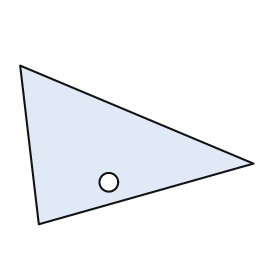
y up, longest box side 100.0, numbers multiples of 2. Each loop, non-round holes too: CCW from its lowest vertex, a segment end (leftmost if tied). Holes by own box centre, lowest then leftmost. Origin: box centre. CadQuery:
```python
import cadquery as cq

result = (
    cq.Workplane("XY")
    .moveTo(-42.0, -34.0)
    .lineTo(50.0, -8.0)
    .lineTo(-50.0, 34.0)
    .close()
    .moveTo(-12.0, -16.0)
    .circle(4.0)
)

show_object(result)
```